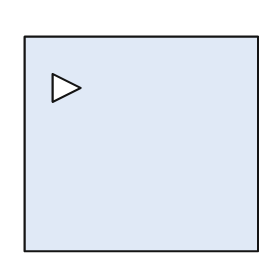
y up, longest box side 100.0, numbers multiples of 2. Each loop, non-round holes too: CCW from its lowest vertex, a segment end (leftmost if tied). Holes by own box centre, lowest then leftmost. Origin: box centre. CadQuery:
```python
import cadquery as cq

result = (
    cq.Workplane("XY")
    .moveTo(-50.0, -46.0)
    .lineTo(50.0, -46.0)
    .lineTo(50.0, 46.0)
    .lineTo(-50.0, 46.0)
    .close()
    .moveTo(-38.0, 18.0)
    .lineTo(-26.0, 24.0)
    .lineTo(-38.0, 30.0)
    .close()
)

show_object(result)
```